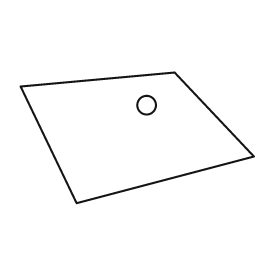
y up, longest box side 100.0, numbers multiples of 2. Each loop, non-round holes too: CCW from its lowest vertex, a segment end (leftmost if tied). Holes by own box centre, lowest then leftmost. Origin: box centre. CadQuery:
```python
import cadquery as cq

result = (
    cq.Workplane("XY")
    .moveTo(-26.0, -28.0)
    .lineTo(50.0, -8.0)
    .lineTo(16.0, 28.0)
    .lineTo(-50.0, 22.0)
    .close()
    .moveTo(4.0, 14.0)
    .circle(4.0)
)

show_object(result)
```